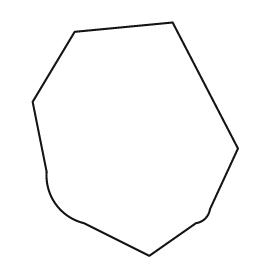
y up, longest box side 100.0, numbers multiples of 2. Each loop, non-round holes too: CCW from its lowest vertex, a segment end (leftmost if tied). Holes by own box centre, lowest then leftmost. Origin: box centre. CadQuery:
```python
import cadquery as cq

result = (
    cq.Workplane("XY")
    .moveTo(6.0, -50.0)
    .lineTo(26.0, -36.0)
    .threePointArc((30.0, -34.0), (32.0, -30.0))
    .lineTo(44.0, -4.0)
    .lineTo(16.0, 50.0)
    .lineTo(-26.0, 46.0)
    .lineTo(-44.0, 16.0)
    .lineTo(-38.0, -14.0)
    .threePointArc((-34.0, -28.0), (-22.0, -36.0))
    .close()
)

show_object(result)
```